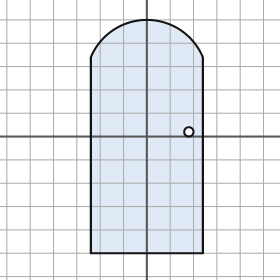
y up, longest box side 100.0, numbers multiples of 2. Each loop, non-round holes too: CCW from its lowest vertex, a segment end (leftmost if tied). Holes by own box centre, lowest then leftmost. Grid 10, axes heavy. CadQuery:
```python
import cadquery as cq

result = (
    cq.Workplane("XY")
    .moveTo(-24.0, -50.0)
    .lineTo(24.0, -50.0)
    .lineTo(24.0, 34.0)
    .threePointArc((0.0, 50.0), (-24.0, 34.0))
    .close()
    .moveTo(18.0, 2.0)
    .circle(2.0)
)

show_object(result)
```